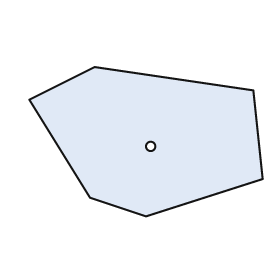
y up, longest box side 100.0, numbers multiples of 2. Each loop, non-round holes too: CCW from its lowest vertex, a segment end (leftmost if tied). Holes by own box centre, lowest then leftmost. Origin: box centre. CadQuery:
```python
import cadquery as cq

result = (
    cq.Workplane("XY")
    .moveTo(0.0, -32.0)
    .lineTo(50.0, -16.0)
    .lineTo(46.0, 22.0)
    .lineTo(-22.0, 32.0)
    .lineTo(-50.0, 18.0)
    .lineTo(-24.0, -24.0)
    .close()
    .moveTo(2.0, -2.0)
    .circle(2.0)
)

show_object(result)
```